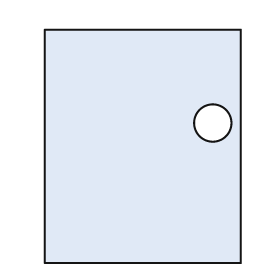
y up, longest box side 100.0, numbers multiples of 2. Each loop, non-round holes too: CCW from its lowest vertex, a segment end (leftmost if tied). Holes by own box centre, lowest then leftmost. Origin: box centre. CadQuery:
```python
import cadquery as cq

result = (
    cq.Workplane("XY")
    .moveTo(-42.0, -50.0)
    .lineTo(42.0, -50.0)
    .lineTo(42.0, 50.0)
    .lineTo(-42.0, 50.0)
    .close()
    .moveTo(30.0, 10.0)
    .circle(8.0)
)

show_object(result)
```